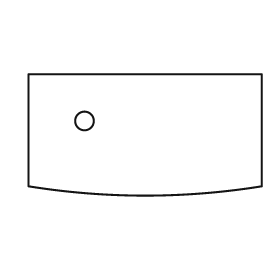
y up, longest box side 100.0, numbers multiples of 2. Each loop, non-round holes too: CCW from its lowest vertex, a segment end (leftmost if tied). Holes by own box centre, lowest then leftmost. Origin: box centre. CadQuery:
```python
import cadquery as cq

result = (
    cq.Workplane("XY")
    .moveTo(-50.0, -22.0)
    .threePointArc((0.0, -26.0), (50.0, -22.0))
    .lineTo(50.0, 26.0)
    .lineTo(-50.0, 26.0)
    .close()
    .moveTo(-26.0, 6.0)
    .circle(4.0)
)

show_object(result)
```